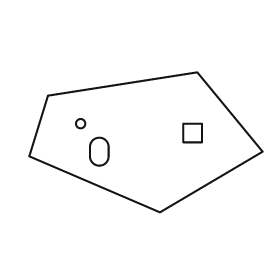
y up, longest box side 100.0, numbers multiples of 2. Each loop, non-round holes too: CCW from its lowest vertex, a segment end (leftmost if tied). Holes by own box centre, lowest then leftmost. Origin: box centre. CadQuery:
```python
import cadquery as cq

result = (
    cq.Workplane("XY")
    .moveTo(6.0, -30.0)
    .lineTo(50.0, -4.0)
    .lineTo(22.0, 30.0)
    .lineTo(-42.0, 20.0)
    .lineTo(-50.0, -6.0)
    .close()
    .moveTo(-24.0, -6.0)
    .threePointArc((-20.0, -10.0), (-16.0, -6.0))
    .lineTo(-16.0, -2.0)
    .threePointArc((-20.0, 2.0), (-24.0, -2.0))
    .close()
    .moveTo(16.0, 0.0)
    .lineTo(24.0, 0.0)
    .lineTo(24.0, 8.0)
    .lineTo(16.0, 8.0)
    .close()
    .moveTo(-28.0, 8.0)
    .circle(2.0)
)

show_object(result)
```